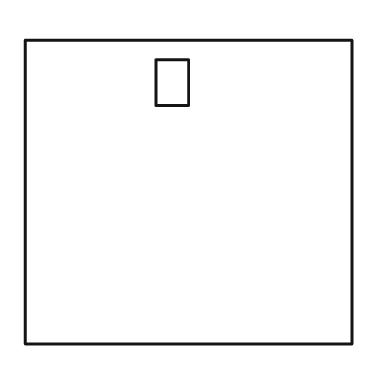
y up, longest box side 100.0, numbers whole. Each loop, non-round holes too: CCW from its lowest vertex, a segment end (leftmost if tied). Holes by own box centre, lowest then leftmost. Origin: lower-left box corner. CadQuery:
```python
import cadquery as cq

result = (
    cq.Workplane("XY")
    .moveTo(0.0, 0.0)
    .lineTo(100.0, 0.0)
    .lineTo(100.0, 93.0)
    .lineTo(0.0, 93.0)
    .close()
    .moveTo(40.0, 73.0)
    .lineTo(50.0, 73.0)
    .lineTo(50.0, 87.0)
    .lineTo(40.0, 87.0)
    .close()
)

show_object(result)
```